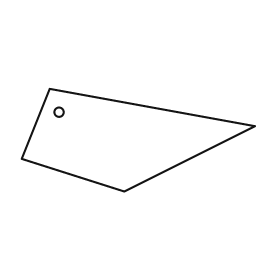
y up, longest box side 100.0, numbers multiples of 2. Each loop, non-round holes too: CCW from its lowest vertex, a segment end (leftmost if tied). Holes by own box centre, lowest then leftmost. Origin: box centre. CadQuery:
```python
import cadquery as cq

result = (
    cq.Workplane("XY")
    .moveTo(-6.0, -22.0)
    .lineTo(50.0, 6.0)
    .lineTo(-38.0, 22.0)
    .lineTo(-50.0, -8.0)
    .close()
    .moveTo(-34.0, 12.0)
    .circle(2.0)
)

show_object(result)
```